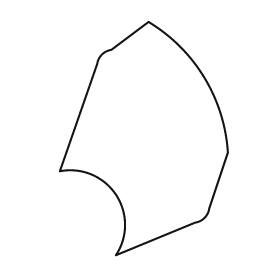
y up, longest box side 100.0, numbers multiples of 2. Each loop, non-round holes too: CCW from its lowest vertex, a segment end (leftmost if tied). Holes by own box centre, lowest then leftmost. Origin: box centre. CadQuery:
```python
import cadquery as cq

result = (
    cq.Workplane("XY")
    .moveTo(-12.0, -50.0)
    .lineTo(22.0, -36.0)
    .threePointArc((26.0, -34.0), (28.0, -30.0))
    .lineTo(36.0, -6.0)
    .threePointArc((26.0, 26.0), (2.0, 50.0))
    .lineTo(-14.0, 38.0)
    .threePointArc((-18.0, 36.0), (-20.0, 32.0))
    .lineTo(-36.0, -14.0)
    .threePointArc((-12.0, -24.0), (-12.0, -50.0))
    .close()
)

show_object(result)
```